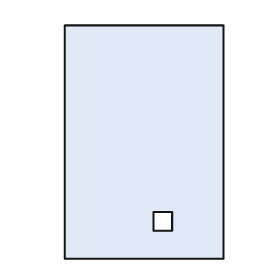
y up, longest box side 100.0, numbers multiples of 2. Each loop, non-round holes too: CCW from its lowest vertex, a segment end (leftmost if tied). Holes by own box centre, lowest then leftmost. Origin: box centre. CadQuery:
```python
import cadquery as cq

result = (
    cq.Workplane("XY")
    .moveTo(-34.0, -50.0)
    .lineTo(34.0, -50.0)
    .lineTo(34.0, 50.0)
    .lineTo(-34.0, 50.0)
    .close()
    .moveTo(4.0, -38.0)
    .lineTo(12.0, -38.0)
    .lineTo(12.0, -30.0)
    .lineTo(4.0, -30.0)
    .close()
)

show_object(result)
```